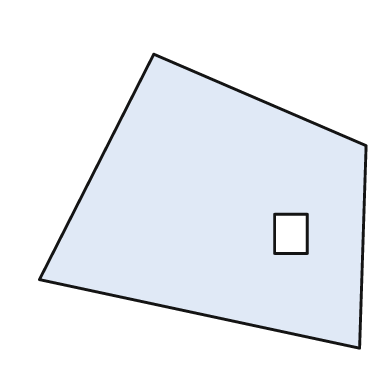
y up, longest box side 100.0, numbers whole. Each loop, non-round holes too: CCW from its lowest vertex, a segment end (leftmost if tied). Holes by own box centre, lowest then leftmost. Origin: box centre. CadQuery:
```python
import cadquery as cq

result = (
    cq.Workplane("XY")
    .moveTo(48.0, -45.0)
    .lineTo(50.0, 17.0)
    .lineTo(-15.0, 45.0)
    .lineTo(-50.0, -24.0)
    .close()
    .moveTo(22.0, -16.0)
    .lineTo(32.0, -16.0)
    .lineTo(32.0, -4.0)
    .lineTo(22.0, -4.0)
    .close()
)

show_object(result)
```